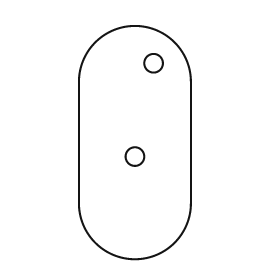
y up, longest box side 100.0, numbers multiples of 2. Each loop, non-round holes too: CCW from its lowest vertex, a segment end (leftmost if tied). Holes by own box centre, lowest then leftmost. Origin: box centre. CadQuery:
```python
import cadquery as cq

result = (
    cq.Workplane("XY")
    .moveTo(-24.0, -26.0)
    .threePointArc((0.0, -50.0), (24.0, -26.0))
    .lineTo(24.0, 26.0)
    .threePointArc((0.0, 50.0), (-24.0, 26.0))
    .close()
    .moveTo(0.0, -6.0)
    .circle(4.0)
    .moveTo(8.0, 34.0)
    .circle(4.0)
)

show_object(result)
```